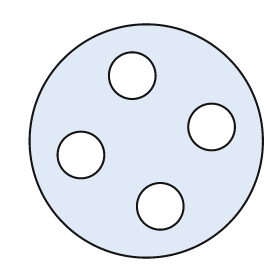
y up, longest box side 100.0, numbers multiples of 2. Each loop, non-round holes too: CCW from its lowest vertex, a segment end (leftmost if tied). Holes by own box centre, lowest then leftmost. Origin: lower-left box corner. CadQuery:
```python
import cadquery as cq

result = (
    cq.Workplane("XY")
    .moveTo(50.0, 50.0)
    .circle(50.0)
    .moveTo(56.0, 22.0)
    .circle(10.0)
    .moveTo(22.0, 44.0)
    .circle(10.0)
    .moveTo(78.0, 56.0)
    .circle(10.0)
    .moveTo(44.0, 78.0)
    .circle(10.0)
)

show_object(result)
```